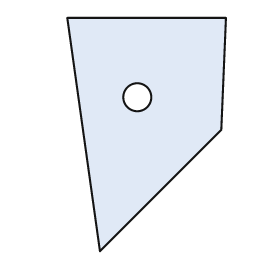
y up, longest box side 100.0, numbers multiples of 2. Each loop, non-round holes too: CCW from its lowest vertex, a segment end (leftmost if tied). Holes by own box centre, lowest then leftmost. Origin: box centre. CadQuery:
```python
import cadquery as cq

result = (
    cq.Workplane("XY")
    .moveTo(-20.0, -50.0)
    .lineTo(32.0, 2.0)
    .lineTo(34.0, 50.0)
    .lineTo(-34.0, 50.0)
    .close()
    .moveTo(-4.0, 16.0)
    .circle(6.0)
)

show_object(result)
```